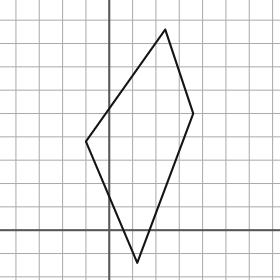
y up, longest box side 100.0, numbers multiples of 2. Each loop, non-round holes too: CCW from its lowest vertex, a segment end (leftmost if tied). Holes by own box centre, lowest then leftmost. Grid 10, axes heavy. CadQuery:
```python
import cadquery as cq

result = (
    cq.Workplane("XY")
    .moveTo(12.0, -14.0)
    .lineTo(36.0, 50.0)
    .lineTo(24.0, 86.0)
    .lineTo(-10.0, 38.0)
    .close()
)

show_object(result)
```